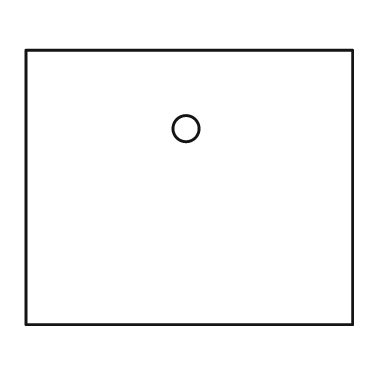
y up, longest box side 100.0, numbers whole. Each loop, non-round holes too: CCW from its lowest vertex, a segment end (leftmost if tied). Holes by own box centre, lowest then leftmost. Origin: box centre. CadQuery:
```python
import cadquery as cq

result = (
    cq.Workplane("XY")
    .moveTo(-50.0, -42.0)
    .lineTo(50.0, -42.0)
    .lineTo(50.0, 42.0)
    .lineTo(-50.0, 42.0)
    .close()
    .moveTo(-1.0, 18.0)
    .circle(4.0)
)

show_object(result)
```